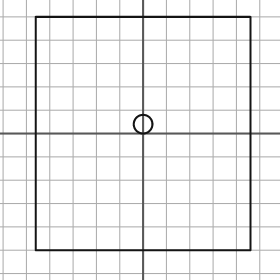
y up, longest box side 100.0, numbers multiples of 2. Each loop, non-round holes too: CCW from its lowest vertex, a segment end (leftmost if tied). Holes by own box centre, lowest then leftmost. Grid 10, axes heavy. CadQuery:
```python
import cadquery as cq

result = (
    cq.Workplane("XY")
    .moveTo(-46.0, -50.0)
    .lineTo(46.0, -50.0)
    .lineTo(46.0, 50.0)
    .lineTo(-46.0, 50.0)
    .close()
    .moveTo(0.0, 4.0)
    .circle(4.0)
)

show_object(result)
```